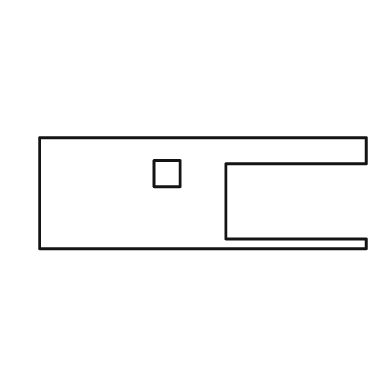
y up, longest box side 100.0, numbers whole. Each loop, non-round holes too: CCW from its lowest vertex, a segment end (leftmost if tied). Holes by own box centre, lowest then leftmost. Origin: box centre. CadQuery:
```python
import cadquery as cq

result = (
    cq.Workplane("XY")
    .moveTo(-50.0, -17.0)
    .lineTo(50.0, -17.0)
    .lineTo(50.0, -14.0)
    .lineTo(7.0, -14.0)
    .lineTo(7.0, 9.0)
    .lineTo(50.0, 9.0)
    .lineTo(50.0, 17.0)
    .lineTo(-50.0, 17.0)
    .close()
    .moveTo(-15.0, 2.0)
    .lineTo(-7.0, 2.0)
    .lineTo(-7.0, 10.0)
    .lineTo(-15.0, 10.0)
    .close()
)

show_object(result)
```